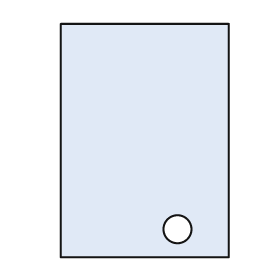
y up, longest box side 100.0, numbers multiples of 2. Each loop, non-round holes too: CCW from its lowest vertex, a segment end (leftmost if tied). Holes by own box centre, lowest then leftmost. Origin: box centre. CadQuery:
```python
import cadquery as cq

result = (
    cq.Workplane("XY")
    .moveTo(-36.0, -50.0)
    .lineTo(36.0, -50.0)
    .lineTo(36.0, 50.0)
    .lineTo(-36.0, 50.0)
    .close()
    .moveTo(14.0, -38.0)
    .circle(6.0)
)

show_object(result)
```